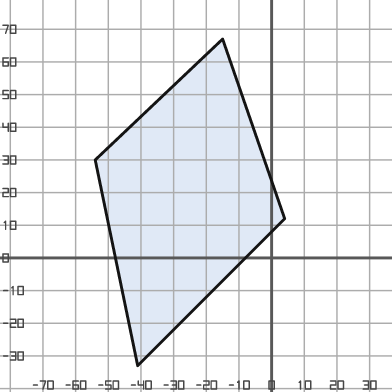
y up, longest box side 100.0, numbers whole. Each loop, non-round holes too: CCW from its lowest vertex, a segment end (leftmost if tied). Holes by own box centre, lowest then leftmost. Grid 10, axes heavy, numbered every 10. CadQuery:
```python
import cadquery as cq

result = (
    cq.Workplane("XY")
    .moveTo(-41.0, -33.0)
    .lineTo(4.0, 12.0)
    .lineTo(-15.0, 67.0)
    .lineTo(-54.0, 30.0)
    .close()
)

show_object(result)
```